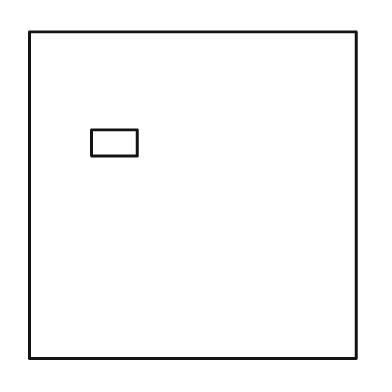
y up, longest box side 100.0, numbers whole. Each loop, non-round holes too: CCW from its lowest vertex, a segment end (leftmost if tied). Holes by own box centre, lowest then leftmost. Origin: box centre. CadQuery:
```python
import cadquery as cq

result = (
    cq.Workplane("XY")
    .moveTo(-50.0, -50.0)
    .lineTo(50.0, -50.0)
    .lineTo(50.0, 50.0)
    .lineTo(-50.0, 50.0)
    .close()
    .moveTo(-31.0, 12.0)
    .lineTo(-17.0, 12.0)
    .lineTo(-17.0, 20.0)
    .lineTo(-31.0, 20.0)
    .close()
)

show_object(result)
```